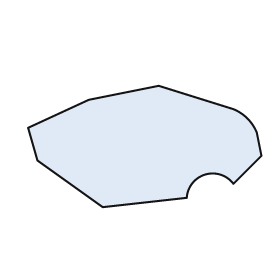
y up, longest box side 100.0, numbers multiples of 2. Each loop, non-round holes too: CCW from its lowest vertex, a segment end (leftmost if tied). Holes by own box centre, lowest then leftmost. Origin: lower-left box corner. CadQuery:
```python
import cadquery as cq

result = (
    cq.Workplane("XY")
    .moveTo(32.0, 0.0)
    .lineTo(68.0, 4.0)
    .threePointArc((76.0, 14.0), (88.0, 10.0))
    .lineTo(100.0, 22.0)
    .lineTo(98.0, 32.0)
    .threePointArc((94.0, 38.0), (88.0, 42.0))
    .lineTo(56.0, 52.0)
    .lineTo(26.0, 46.0)
    .lineTo(0.0, 34.0)
    .lineTo(4.0, 20.0)
    .close()
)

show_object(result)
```